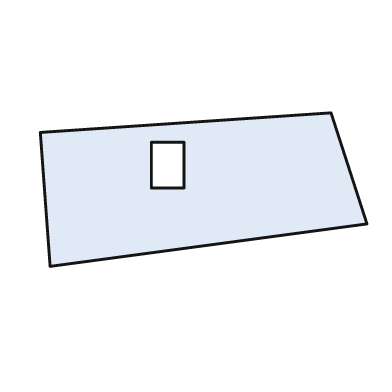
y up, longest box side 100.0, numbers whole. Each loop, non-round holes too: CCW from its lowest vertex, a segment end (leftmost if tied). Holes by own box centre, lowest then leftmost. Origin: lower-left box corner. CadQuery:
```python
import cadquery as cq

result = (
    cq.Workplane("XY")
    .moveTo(3.0, 0.0)
    .lineTo(100.0, 13.0)
    .lineTo(89.0, 47.0)
    .lineTo(0.0, 41.0)
    .close()
    .moveTo(34.0, 24.0)
    .lineTo(44.0, 24.0)
    .lineTo(44.0, 38.0)
    .lineTo(34.0, 38.0)
    .close()
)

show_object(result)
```